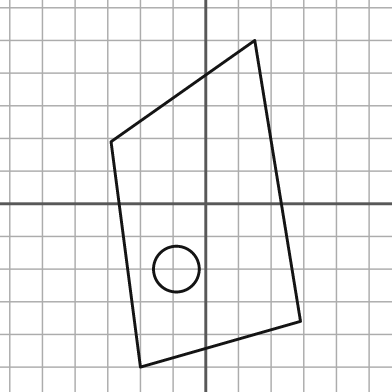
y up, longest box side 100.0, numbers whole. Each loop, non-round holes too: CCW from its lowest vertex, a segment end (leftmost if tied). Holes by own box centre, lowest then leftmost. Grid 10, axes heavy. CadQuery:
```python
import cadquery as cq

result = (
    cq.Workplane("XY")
    .moveTo(-20.0, -50.0)
    .lineTo(29.0, -36.0)
    .lineTo(15.0, 50.0)
    .lineTo(-29.0, 19.0)
    .close()
    .moveTo(-9.0, -20.0)
    .circle(7.0)
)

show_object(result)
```